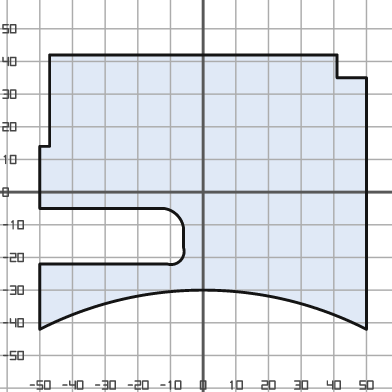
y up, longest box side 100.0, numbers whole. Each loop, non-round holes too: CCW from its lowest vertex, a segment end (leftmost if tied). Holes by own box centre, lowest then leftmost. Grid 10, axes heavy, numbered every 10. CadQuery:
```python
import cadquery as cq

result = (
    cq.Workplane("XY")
    .moveTo(-50.0, -42.0)
    .threePointArc((0.0, -30.0), (50.0, -42.0))
    .lineTo(50.0, 35.0)
    .lineTo(41.0, 35.0)
    .lineTo(41.0, 42.0)
    .lineTo(-47.0, 42.0)
    .lineTo(-47.0, 14.0)
    .lineTo(-50.0, 14.0)
    .lineTo(-50.0, -5.0)
    .lineTo(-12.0, -5.0)
    .threePointArc((-8.0, -7.0), (-6.0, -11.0))
    .lineTo(-6.0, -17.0)
    .threePointArc((-7.0, -21.0), (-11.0, -22.0))
    .lineTo(-50.0, -22.0)
    .close()
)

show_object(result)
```